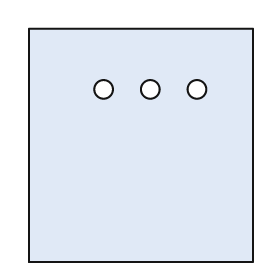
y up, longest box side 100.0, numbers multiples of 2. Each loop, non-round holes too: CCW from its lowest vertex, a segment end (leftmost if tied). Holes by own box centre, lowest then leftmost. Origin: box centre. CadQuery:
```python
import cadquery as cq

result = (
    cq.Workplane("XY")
    .moveTo(-48.0, -50.0)
    .lineTo(48.0, -50.0)
    .lineTo(48.0, 50.0)
    .lineTo(-48.0, 50.0)
    .close()
    .moveTo(-16.0, 24.0)
    .circle(4.0)
    .moveTo(4.0, 24.0)
    .circle(4.0)
    .moveTo(24.0, 24.0)
    .circle(4.0)
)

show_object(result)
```